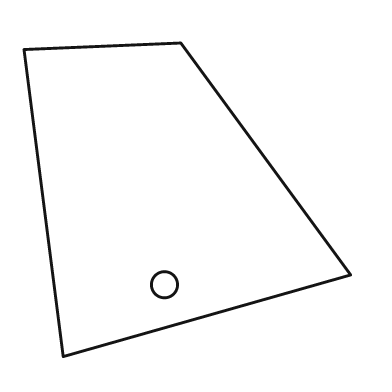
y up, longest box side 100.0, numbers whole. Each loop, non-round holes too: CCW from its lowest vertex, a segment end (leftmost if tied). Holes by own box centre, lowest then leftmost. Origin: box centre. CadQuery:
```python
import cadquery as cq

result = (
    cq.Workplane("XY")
    .moveTo(-38.0, -48.0)
    .lineTo(50.0, -23.0)
    .lineTo(-2.0, 48.0)
    .lineTo(-50.0, 46.0)
    .close()
    .moveTo(-7.0, -26.0)
    .circle(4.0)
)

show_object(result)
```